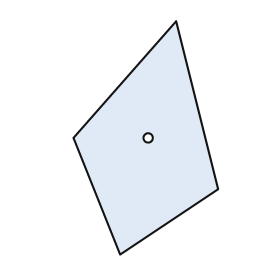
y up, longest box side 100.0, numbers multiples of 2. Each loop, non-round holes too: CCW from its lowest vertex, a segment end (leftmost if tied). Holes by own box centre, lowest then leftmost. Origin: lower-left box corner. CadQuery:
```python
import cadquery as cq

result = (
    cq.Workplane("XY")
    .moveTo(20.0, 0.0)
    .lineTo(62.0, 28.0)
    .lineTo(44.0, 100.0)
    .lineTo(0.0, 50.0)
    .close()
    .moveTo(32.0, 50.0)
    .circle(2.0)
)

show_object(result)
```